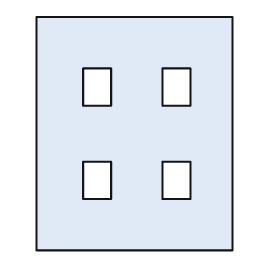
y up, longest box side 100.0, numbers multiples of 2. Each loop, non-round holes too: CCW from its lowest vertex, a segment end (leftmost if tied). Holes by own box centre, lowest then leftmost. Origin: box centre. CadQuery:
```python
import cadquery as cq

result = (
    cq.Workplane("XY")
    .moveTo(-42.0, -50.0)
    .lineTo(42.0, -50.0)
    .lineTo(42.0, 50.0)
    .lineTo(-42.0, 50.0)
    .close()
    .moveTo(-22.0, -28.0)
    .lineTo(-10.0, -28.0)
    .lineTo(-10.0, -12.0)
    .lineTo(-22.0, -12.0)
    .close()
    .moveTo(12.0, -28.0)
    .lineTo(24.0, -28.0)
    .lineTo(24.0, -12.0)
    .lineTo(12.0, -12.0)
    .close()
    .moveTo(-22.0, 12.0)
    .lineTo(-10.0, 12.0)
    .lineTo(-10.0, 28.0)
    .lineTo(-22.0, 28.0)
    .close()
    .moveTo(12.0, 12.0)
    .lineTo(24.0, 12.0)
    .lineTo(24.0, 28.0)
    .lineTo(12.0, 28.0)
    .close()
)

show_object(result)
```